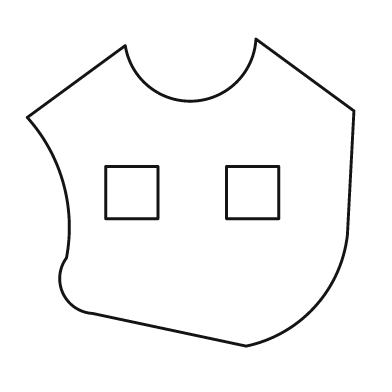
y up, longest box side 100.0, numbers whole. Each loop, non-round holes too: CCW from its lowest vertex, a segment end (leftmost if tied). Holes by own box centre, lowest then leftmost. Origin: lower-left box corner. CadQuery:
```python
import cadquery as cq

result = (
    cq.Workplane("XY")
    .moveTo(67.0, 0.0)
    .threePointArc((88.0, 12.0), (98.0, 34.0))
    .lineTo(100.0, 72.0)
    .lineTo(70.0, 94.0)
    .threePointArc((51.0, 75.0), (30.0, 92.0))
    .lineTo(0.0, 70.0)
    .threePointArc((11.0, 50.0), (12.0, 27.0))
    .threePointArc((11.0, 16.0), (20.0, 10.0))
    .close()
    .moveTo(24.0, 39.0)
    .lineTo(40.0, 39.0)
    .lineTo(40.0, 55.0)
    .lineTo(24.0, 55.0)
    .close()
    .moveTo(61.0, 39.0)
    .lineTo(77.0, 39.0)
    .lineTo(77.0, 55.0)
    .lineTo(61.0, 55.0)
    .close()
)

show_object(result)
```